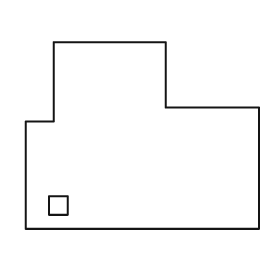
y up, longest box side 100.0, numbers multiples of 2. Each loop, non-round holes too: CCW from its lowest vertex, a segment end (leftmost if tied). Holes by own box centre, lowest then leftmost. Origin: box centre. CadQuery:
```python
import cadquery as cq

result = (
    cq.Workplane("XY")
    .moveTo(-50.0, -40.0)
    .lineTo(50.0, -40.0)
    .lineTo(50.0, 12.0)
    .lineTo(10.0, 12.0)
    .lineTo(10.0, 40.0)
    .lineTo(-38.0, 40.0)
    .lineTo(-38.0, 6.0)
    .lineTo(-50.0, 6.0)
    .close()
    .moveTo(-40.0, -34.0)
    .lineTo(-32.0, -34.0)
    .lineTo(-32.0, -26.0)
    .lineTo(-40.0, -26.0)
    .close()
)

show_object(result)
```